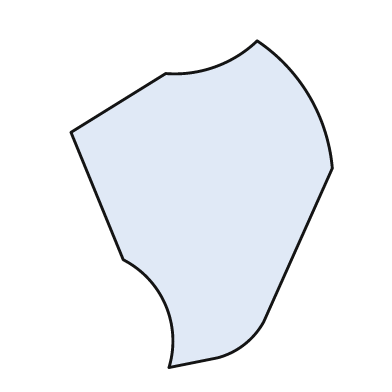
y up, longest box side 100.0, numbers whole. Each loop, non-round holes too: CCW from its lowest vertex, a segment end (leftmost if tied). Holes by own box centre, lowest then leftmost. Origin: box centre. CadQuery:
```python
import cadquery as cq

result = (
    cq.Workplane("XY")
    .moveTo(-10.0, -50.0)
    .lineTo(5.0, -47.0)
    .threePointArc((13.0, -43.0), (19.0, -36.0))
    .lineTo(40.0, 11.0)
    .threePointArc((33.0, 33.0), (17.0, 50.0))
    .threePointArc((4.0, 42.0), (-11.0, 40.0))
    .lineTo(-40.0, 22.0)
    .lineTo(-24.0, -17.0)
    .threePointArc((-11.0, -31.0), (-10.0, -50.0))
    .close()
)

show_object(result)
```